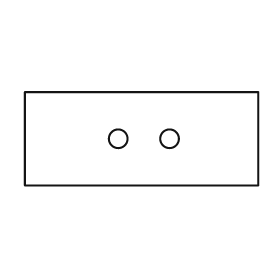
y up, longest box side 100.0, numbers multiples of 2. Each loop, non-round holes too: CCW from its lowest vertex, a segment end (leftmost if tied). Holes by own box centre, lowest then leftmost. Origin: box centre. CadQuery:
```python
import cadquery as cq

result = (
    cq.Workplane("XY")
    .moveTo(-50.0, -20.0)
    .lineTo(50.0, -20.0)
    .lineTo(50.0, 20.0)
    .lineTo(-50.0, 20.0)
    .close()
    .moveTo(-10.0, 0.0)
    .circle(4.0)
    .moveTo(12.0, 0.0)
    .circle(4.0)
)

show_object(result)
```